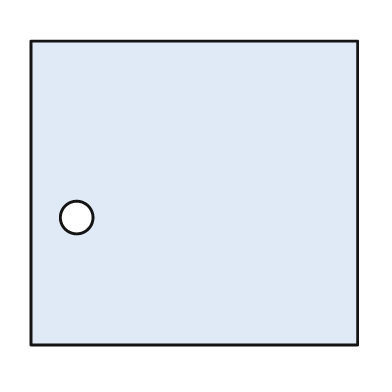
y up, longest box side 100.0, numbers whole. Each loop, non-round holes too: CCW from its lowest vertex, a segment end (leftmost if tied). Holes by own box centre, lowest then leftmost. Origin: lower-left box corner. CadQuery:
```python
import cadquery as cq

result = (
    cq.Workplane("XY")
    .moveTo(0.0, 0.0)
    .lineTo(100.0, 0.0)
    .lineTo(100.0, 93.0)
    .lineTo(0.0, 93.0)
    .close()
    .moveTo(14.0, 39.0)
    .circle(5.0)
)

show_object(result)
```